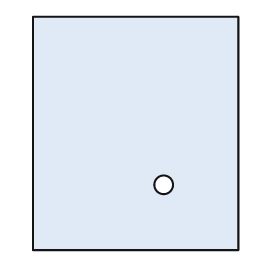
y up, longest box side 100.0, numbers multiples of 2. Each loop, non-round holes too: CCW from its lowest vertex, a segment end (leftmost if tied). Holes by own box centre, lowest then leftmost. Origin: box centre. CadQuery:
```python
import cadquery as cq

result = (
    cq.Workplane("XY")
    .moveTo(-44.0, -50.0)
    .lineTo(44.0, -50.0)
    .lineTo(44.0, 50.0)
    .lineTo(-44.0, 50.0)
    .close()
    .moveTo(12.0, -22.0)
    .circle(4.0)
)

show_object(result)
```